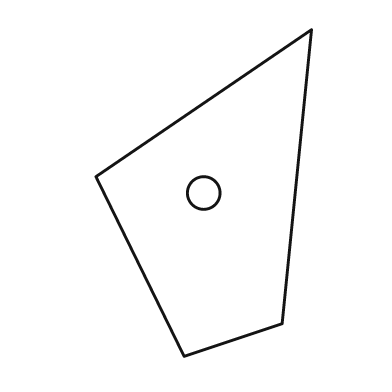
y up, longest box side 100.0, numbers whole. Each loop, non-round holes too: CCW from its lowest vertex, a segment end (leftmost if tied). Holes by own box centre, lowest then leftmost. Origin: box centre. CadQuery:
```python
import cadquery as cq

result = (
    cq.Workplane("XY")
    .moveTo(-6.0, -50.0)
    .lineTo(24.0, -40.0)
    .lineTo(33.0, 50.0)
    .lineTo(-33.0, 5.0)
    .close()
    .moveTo(0.0, 0.0)
    .circle(5.0)
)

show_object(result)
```